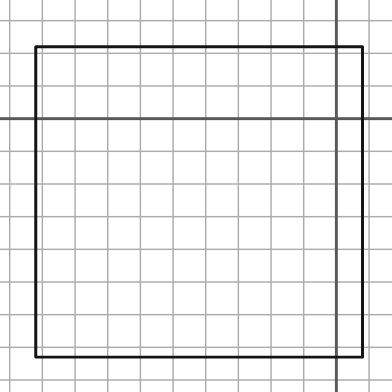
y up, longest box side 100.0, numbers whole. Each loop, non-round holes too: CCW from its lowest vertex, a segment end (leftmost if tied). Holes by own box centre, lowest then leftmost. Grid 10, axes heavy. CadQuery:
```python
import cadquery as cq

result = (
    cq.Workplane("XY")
    .moveTo(-92.0, -73.0)
    .lineTo(8.0, -73.0)
    .lineTo(8.0, 22.0)
    .lineTo(-92.0, 22.0)
    .close()
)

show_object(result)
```